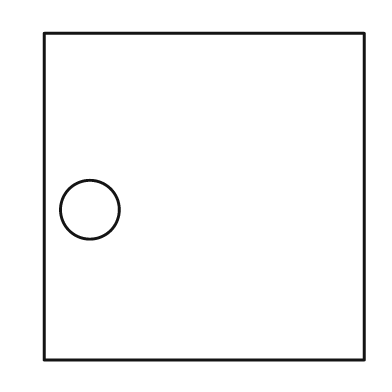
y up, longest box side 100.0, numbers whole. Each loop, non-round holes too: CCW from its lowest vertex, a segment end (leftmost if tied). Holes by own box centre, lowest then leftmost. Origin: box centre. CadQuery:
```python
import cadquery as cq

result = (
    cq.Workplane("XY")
    .moveTo(-49.0, -50.0)
    .lineTo(49.0, -50.0)
    .lineTo(49.0, 50.0)
    .lineTo(-49.0, 50.0)
    .close()
    .moveTo(-35.0, -4.0)
    .circle(9.0)
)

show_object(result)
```